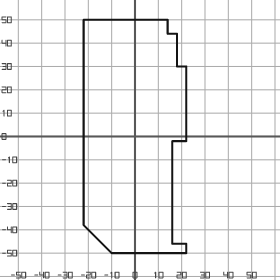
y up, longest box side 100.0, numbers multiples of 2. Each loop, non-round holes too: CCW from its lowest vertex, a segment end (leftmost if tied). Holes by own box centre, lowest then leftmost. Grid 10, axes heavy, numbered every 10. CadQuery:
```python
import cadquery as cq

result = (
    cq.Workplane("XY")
    .moveTo(-10.0, -50.0)
    .lineTo(22.0, -50.0)
    .lineTo(22.0, -46.0)
    .lineTo(16.0, -46.0)
    .lineTo(16.0, -2.0)
    .lineTo(22.0, -2.0)
    .lineTo(22.0, 30.0)
    .lineTo(18.0, 30.0)
    .lineTo(18.0, 44.0)
    .lineTo(14.0, 44.0)
    .lineTo(14.0, 50.0)
    .lineTo(-22.0, 50.0)
    .lineTo(-22.0, -38.0)
    .close()
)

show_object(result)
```